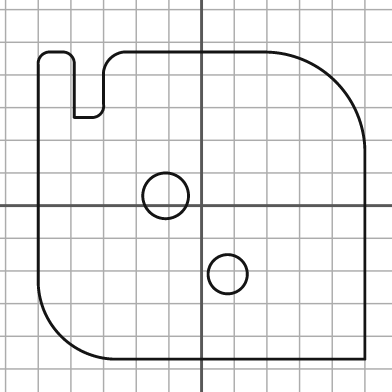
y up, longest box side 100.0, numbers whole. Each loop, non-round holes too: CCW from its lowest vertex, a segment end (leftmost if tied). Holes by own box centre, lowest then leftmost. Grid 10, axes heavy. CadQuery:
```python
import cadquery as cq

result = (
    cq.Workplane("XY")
    .moveTo(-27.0, -47.0)
    .lineTo(50.0, -47.0)
    .lineTo(50.0, 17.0)
    .threePointArc((41.0, 38.0), (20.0, 47.0))
    .lineTo(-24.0, 47.0)
    .threePointArc((-28.0, 45.0), (-30.0, 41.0))
    .lineTo(-30.0, 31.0)
    .threePointArc((-31.0, 28.0), (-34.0, 27.0))
    .lineTo(-39.0, 27.0)
    .lineTo(-39.0, 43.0)
    .threePointArc((-40.0, 46.0), (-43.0, 47.0))
    .lineTo(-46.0, 47.0)
    .threePointArc((-49.0, 46.0), (-50.0, 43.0))
    .lineTo(-50.0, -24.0)
    .threePointArc((-43.0, -40.0), (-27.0, -47.0))
    .close()
    .moveTo(8.0, -21.0)
    .circle(6.0)
    .moveTo(-11.0, 3.0)
    .circle(7.0)
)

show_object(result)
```